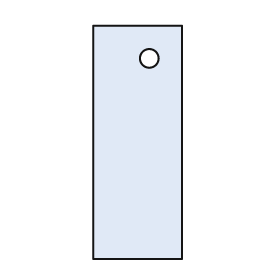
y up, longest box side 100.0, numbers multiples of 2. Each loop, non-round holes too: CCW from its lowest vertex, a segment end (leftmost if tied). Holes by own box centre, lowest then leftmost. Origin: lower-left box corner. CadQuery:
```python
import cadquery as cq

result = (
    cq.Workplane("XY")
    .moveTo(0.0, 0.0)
    .lineTo(38.0, 0.0)
    .lineTo(38.0, 100.0)
    .lineTo(0.0, 100.0)
    .close()
    .moveTo(24.0, 86.0)
    .circle(4.0)
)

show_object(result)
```